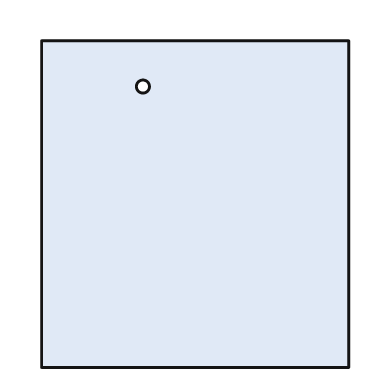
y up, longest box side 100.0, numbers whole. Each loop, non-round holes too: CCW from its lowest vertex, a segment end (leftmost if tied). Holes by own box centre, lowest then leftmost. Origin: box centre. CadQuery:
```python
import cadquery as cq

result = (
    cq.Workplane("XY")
    .moveTo(-47.0, -50.0)
    .lineTo(47.0, -50.0)
    .lineTo(47.0, 50.0)
    .lineTo(-47.0, 50.0)
    .close()
    .moveTo(-16.0, 36.0)
    .circle(2.0)
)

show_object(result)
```